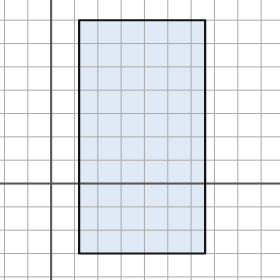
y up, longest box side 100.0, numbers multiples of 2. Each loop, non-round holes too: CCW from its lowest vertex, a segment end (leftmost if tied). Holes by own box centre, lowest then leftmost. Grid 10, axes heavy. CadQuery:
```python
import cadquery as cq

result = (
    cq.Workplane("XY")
    .moveTo(12.0, -30.0)
    .lineTo(66.0, -30.0)
    .lineTo(66.0, 70.0)
    .lineTo(12.0, 70.0)
    .close()
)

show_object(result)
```